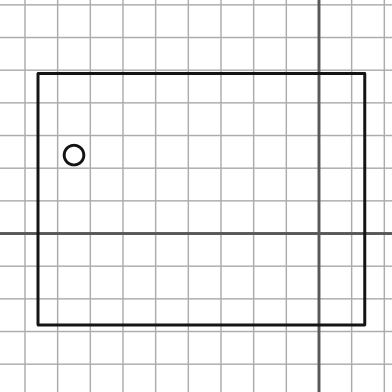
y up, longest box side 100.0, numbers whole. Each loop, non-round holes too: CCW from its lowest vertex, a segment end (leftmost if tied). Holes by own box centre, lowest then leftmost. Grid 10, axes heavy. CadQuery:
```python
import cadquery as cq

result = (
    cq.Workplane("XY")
    .moveTo(-86.0, -28.0)
    .lineTo(14.0, -28.0)
    .lineTo(14.0, 49.0)
    .lineTo(-86.0, 49.0)
    .close()
    .moveTo(-75.0, 24.0)
    .circle(3.0)
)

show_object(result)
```